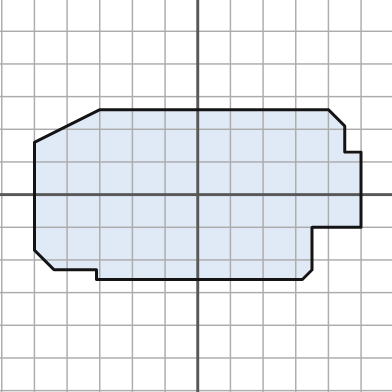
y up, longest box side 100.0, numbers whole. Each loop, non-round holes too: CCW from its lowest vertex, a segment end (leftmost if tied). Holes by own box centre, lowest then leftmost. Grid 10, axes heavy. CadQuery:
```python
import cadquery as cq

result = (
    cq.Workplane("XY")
    .moveTo(-31.0, -26.0)
    .lineTo(32.0, -26.0)
    .lineTo(35.0, -23.0)
    .lineTo(35.0, -10.0)
    .lineTo(50.0, -10.0)
    .lineTo(50.0, 13.0)
    .lineTo(45.0, 13.0)
    .lineTo(45.0, 21.0)
    .lineTo(40.0, 26.0)
    .lineTo(-30.0, 26.0)
    .lineTo(-50.0, 16.0)
    .lineTo(-50.0, -17.0)
    .lineTo(-44.0, -23.0)
    .lineTo(-31.0, -23.0)
    .close()
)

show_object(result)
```